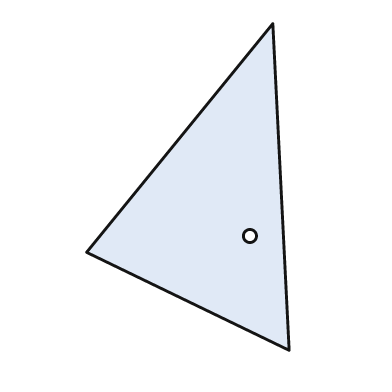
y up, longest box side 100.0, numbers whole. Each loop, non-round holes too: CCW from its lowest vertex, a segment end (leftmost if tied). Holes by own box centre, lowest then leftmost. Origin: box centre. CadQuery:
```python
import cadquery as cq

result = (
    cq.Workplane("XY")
    .moveTo(31.0, -50.0)
    .lineTo(26.0, 50.0)
    .lineTo(-31.0, -20.0)
    .close()
    .moveTo(19.0, -15.0)
    .circle(2.0)
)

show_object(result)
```